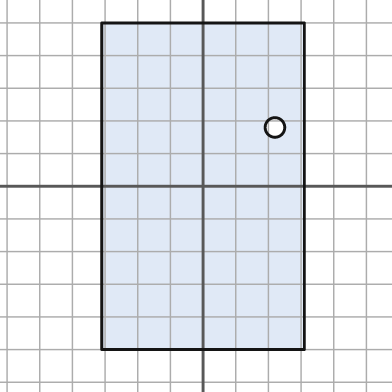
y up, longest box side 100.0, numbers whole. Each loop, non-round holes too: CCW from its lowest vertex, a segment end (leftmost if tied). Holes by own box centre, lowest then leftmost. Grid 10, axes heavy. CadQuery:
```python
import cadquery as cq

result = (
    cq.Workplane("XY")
    .moveTo(-31.0, -50.0)
    .lineTo(31.0, -50.0)
    .lineTo(31.0, 50.0)
    .lineTo(-31.0, 50.0)
    .close()
    .moveTo(22.0, 18.0)
    .circle(3.0)
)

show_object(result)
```